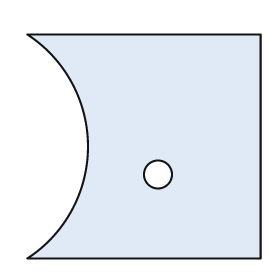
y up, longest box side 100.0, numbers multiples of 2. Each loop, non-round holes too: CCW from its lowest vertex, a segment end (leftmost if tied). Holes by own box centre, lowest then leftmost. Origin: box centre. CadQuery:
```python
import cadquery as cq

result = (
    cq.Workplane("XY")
    .moveTo(-50.0, -48.0)
    .lineTo(50.0, -48.0)
    .lineTo(50.0, 48.0)
    .lineTo(-50.0, 48.0)
    .threePointArc((-24.0, 0.0), (-50.0, -48.0))
    .close()
    .moveTo(6.0, -12.0)
    .circle(6.0)
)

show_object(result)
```